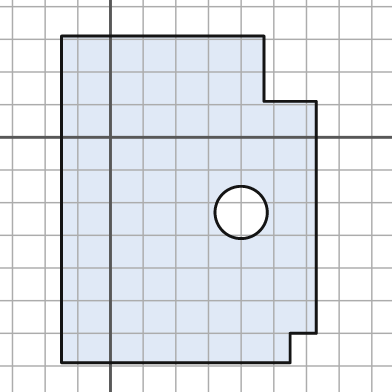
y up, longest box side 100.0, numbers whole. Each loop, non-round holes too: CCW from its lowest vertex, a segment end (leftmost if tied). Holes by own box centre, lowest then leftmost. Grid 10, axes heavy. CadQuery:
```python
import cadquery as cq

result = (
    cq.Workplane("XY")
    .moveTo(-15.0, -69.0)
    .lineTo(55.0, -69.0)
    .lineTo(55.0, -60.0)
    .lineTo(63.0, -60.0)
    .lineTo(63.0, 11.0)
    .lineTo(47.0, 11.0)
    .lineTo(47.0, 31.0)
    .lineTo(-15.0, 31.0)
    .close()
    .moveTo(40.0, -23.0)
    .circle(8.0)
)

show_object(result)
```